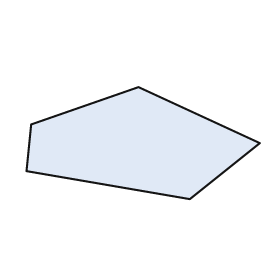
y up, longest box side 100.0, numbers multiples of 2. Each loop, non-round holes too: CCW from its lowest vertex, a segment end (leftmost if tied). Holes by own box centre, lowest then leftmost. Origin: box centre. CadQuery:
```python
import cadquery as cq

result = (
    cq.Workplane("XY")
    .moveTo(20.0, -24.0)
    .lineTo(50.0, 0.0)
    .lineTo(-2.0, 24.0)
    .lineTo(-48.0, 8.0)
    .lineTo(-50.0, -12.0)
    .close()
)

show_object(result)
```